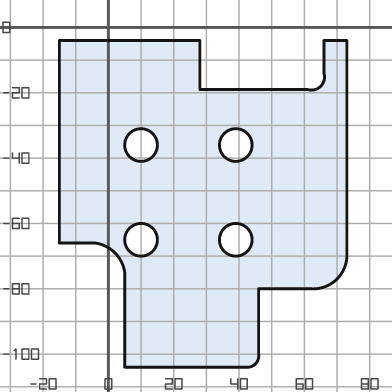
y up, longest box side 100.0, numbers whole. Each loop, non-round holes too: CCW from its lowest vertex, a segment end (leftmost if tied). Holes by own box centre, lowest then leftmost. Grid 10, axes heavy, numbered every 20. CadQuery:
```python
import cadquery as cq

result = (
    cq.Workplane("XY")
    .moveTo(5.0, -104.0)
    .lineTo(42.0, -104.0)
    .threePointArc((45.0, -103.0), (46.0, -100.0))
    .lineTo(46.0, -80.0)
    .lineTo(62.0, -80.0)
    .threePointArc((70.0, -77.0), (73.0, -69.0))
    .lineTo(73.0, -4.0)
    .lineTo(66.0, -4.0)
    .lineTo(66.0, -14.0)
    .threePointArc((65.0, -18.0), (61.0, -19.0))
    .lineTo(28.0, -19.0)
    .lineTo(28.0, -4.0)
    .lineTo(-15.0, -4.0)
    .lineTo(-15.0, -66.0)
    .lineTo(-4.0, -66.0)
    .threePointArc((2.0, -69.0), (5.0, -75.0))
    .close()
    .moveTo(10.0, -65.0)
    .circle(5.0)
    .moveTo(39.0, -65.0)
    .circle(5.0)
    .moveTo(10.0, -36.0)
    .circle(5.0)
    .moveTo(39.0, -36.0)
    .circle(5.0)
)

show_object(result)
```